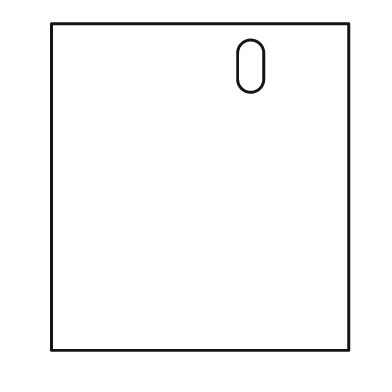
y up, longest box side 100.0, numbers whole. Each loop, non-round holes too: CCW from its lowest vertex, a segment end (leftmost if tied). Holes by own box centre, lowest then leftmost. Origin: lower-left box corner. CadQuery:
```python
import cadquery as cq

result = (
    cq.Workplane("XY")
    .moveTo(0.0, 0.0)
    .lineTo(91.0, 0.0)
    .lineTo(91.0, 100.0)
    .lineTo(0.0, 100.0)
    .close()
    .moveTo(57.0, 83.0)
    .threePointArc((61.0, 79.0), (65.0, 83.0))
    .lineTo(65.0, 91.0)
    .threePointArc((61.0, 95.0), (57.0, 91.0))
    .close()
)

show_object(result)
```